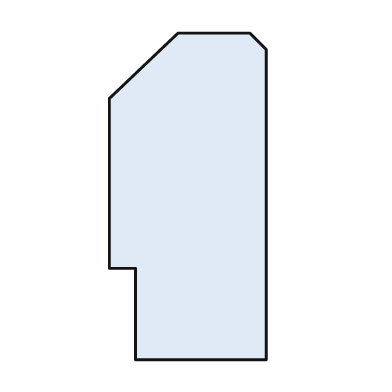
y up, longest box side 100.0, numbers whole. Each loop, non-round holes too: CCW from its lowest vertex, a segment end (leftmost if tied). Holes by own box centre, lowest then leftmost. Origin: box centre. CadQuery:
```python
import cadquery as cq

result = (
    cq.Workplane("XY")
    .moveTo(-16.0, -50.0)
    .lineTo(24.0, -50.0)
    .lineTo(24.0, 45.0)
    .lineTo(19.0, 50.0)
    .lineTo(-3.0, 50.0)
    .lineTo(-24.0, 30.0)
    .lineTo(-24.0, -22.0)
    .lineTo(-16.0, -22.0)
    .close()
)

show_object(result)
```